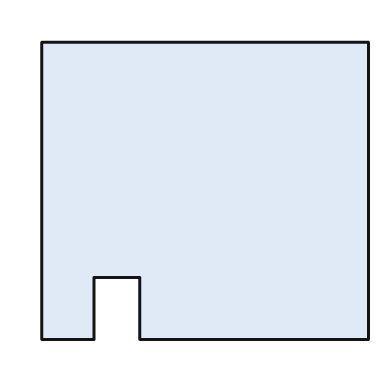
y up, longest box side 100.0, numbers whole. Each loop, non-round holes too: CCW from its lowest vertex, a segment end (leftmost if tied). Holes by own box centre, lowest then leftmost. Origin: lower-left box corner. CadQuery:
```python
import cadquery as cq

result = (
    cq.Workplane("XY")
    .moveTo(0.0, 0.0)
    .lineTo(16.0, 0.0)
    .lineTo(16.0, 19.0)
    .lineTo(30.0, 19.0)
    .lineTo(30.0, 0.0)
    .lineTo(100.0, 0.0)
    .lineTo(100.0, 91.0)
    .lineTo(0.0, 91.0)
    .close()
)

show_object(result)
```